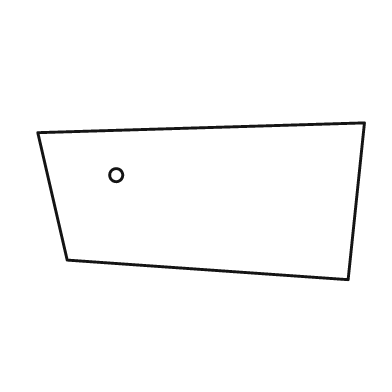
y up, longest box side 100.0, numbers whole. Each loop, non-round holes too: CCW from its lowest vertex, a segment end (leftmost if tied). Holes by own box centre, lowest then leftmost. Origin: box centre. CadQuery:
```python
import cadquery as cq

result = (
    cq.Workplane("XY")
    .moveTo(45.0, -24.0)
    .lineTo(50.0, 24.0)
    .lineTo(-50.0, 21.0)
    .lineTo(-41.0, -18.0)
    .close()
    .moveTo(-26.0, 8.0)
    .circle(2.0)
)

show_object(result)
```